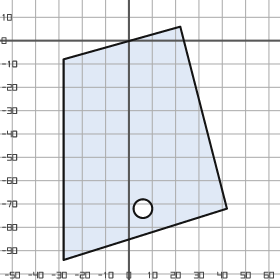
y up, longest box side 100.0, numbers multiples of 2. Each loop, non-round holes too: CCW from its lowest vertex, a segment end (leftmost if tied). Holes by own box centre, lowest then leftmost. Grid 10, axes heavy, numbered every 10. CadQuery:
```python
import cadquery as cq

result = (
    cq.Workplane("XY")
    .moveTo(-28.0, -94.0)
    .lineTo(42.0, -72.0)
    .lineTo(22.0, 6.0)
    .lineTo(-28.0, -8.0)
    .close()
    .moveTo(6.0, -72.0)
    .circle(4.0)
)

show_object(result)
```